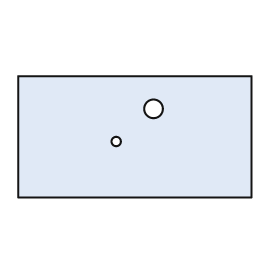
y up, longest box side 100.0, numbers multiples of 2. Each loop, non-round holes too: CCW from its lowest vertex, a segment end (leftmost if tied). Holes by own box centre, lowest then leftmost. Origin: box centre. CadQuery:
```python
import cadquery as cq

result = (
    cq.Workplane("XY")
    .moveTo(-50.0, -26.0)
    .lineTo(50.0, -26.0)
    .lineTo(50.0, 26.0)
    .lineTo(-50.0, 26.0)
    .close()
    .moveTo(-8.0, -2.0)
    .circle(2.0)
    .moveTo(8.0, 12.0)
    .circle(4.0)
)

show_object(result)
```